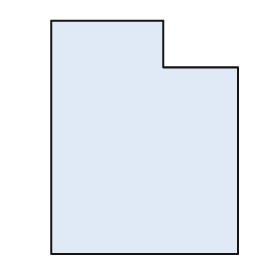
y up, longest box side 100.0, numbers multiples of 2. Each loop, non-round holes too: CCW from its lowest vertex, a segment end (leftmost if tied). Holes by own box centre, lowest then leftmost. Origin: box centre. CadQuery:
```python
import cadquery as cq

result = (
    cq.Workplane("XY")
    .moveTo(-40.0, -50.0)
    .lineTo(40.0, -50.0)
    .lineTo(40.0, 30.0)
    .lineTo(8.0, 30.0)
    .lineTo(8.0, 50.0)
    .lineTo(-40.0, 50.0)
    .close()
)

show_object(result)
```